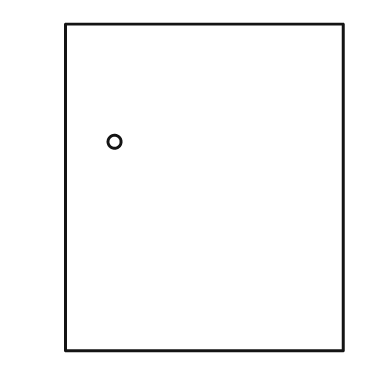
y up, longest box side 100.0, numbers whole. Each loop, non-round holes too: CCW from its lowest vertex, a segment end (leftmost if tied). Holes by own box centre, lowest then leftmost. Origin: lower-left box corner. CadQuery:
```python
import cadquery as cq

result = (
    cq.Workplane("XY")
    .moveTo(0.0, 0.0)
    .lineTo(85.0, 0.0)
    .lineTo(85.0, 100.0)
    .lineTo(0.0, 100.0)
    .close()
    .moveTo(15.0, 64.0)
    .circle(2.0)
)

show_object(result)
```